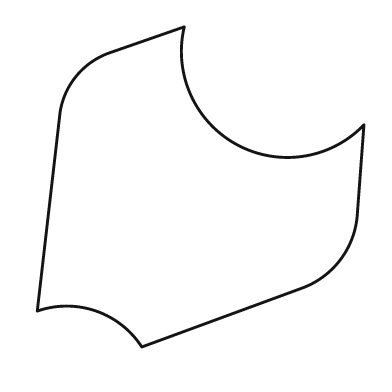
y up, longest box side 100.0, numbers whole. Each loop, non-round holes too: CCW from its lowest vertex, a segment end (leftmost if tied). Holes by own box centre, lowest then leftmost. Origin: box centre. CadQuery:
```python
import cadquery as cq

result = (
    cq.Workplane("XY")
    .moveTo(-18.0, -49.0)
    .lineTo(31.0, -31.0)
    .threePointArc((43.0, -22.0), (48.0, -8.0))
    .lineTo(50.0, 19.0)
    .threePointArc((11.0, 13.0), (-5.0, 49.0))
    .lineTo(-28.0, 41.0)
    .threePointArc((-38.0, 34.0), (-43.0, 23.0))
    .lineTo(-50.0, -38.0)
    .threePointArc((-32.0, -38.0), (-18.0, -49.0))
    .close()
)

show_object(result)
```